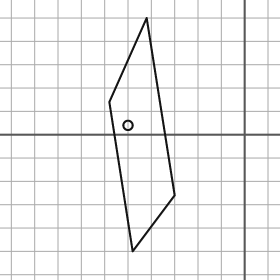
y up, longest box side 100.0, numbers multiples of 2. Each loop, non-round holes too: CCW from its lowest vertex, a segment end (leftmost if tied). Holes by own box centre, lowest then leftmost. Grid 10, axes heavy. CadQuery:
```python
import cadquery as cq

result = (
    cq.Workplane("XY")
    .moveTo(-48.0, -50.0)
    .lineTo(-30.0, -26.0)
    .lineTo(-42.0, 50.0)
    .lineTo(-58.0, 14.0)
    .close()
    .moveTo(-50.0, 4.0)
    .circle(2.0)
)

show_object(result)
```